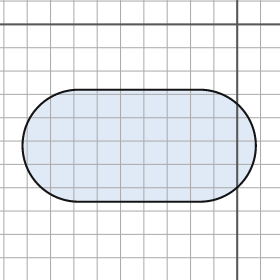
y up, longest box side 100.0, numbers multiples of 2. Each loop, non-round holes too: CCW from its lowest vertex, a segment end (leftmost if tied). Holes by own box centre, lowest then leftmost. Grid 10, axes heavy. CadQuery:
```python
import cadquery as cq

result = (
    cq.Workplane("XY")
    .moveTo(-68.0, -76.0)
    .lineTo(-16.0, -76.0)
    .threePointArc((8.0, -52.0), (-16.0, -28.0))
    .lineTo(-68.0, -28.0)
    .threePointArc((-92.0, -52.0), (-68.0, -76.0))
    .close()
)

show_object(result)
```